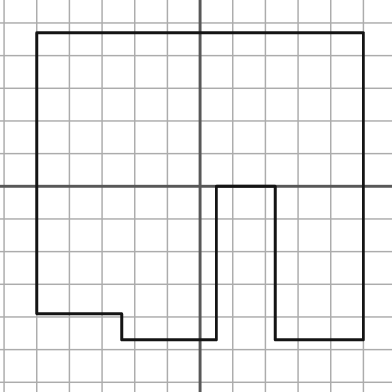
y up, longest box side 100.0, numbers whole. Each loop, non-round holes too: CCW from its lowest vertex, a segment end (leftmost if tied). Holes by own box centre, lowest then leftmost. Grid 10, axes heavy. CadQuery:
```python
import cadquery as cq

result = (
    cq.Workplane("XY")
    .moveTo(-24.0, -47.0)
    .lineTo(5.0, -47.0)
    .lineTo(5.0, 0.0)
    .lineTo(23.0, 0.0)
    .lineTo(23.0, -47.0)
    .lineTo(50.0, -47.0)
    .lineTo(50.0, 47.0)
    .lineTo(-50.0, 47.0)
    .lineTo(-50.0, -39.0)
    .lineTo(-24.0, -39.0)
    .close()
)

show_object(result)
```